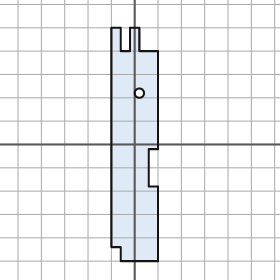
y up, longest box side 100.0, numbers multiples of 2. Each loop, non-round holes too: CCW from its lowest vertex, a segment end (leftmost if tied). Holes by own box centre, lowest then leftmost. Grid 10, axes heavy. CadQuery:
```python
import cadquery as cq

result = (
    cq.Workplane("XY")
    .moveTo(-6.0, -50.0)
    .lineTo(10.0, -50.0)
    .lineTo(10.0, -18.0)
    .lineTo(6.0, -18.0)
    .lineTo(6.0, -2.0)
    .lineTo(10.0, -2.0)
    .lineTo(10.0, 40.0)
    .lineTo(2.0, 40.0)
    .lineTo(2.0, 50.0)
    .lineTo(-2.0, 50.0)
    .lineTo(-2.0, 40.0)
    .lineTo(-6.0, 40.0)
    .lineTo(-6.0, 50.0)
    .lineTo(-10.0, 50.0)
    .lineTo(-10.0, -44.0)
    .lineTo(-6.0, -44.0)
    .close()
    .moveTo(2.0, 22.0)
    .circle(2.0)
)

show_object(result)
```